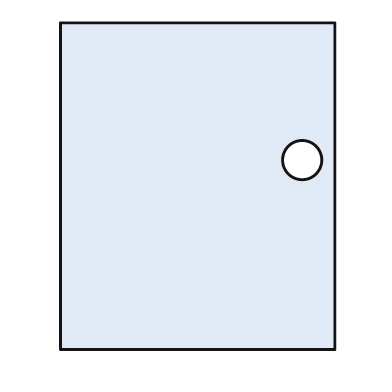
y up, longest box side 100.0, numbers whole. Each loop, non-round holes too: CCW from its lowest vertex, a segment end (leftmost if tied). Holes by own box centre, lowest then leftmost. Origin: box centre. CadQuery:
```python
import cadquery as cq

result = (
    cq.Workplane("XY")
    .moveTo(-42.0, -50.0)
    .lineTo(42.0, -50.0)
    .lineTo(42.0, 50.0)
    .lineTo(-42.0, 50.0)
    .close()
    .moveTo(32.0, 8.0)
    .circle(6.0)
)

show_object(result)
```